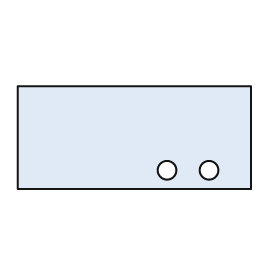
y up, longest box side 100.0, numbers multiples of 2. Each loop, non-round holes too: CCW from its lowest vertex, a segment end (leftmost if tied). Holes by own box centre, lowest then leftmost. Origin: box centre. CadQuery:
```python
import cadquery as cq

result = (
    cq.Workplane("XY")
    .moveTo(-50.0, -22.0)
    .lineTo(50.0, -22.0)
    .lineTo(50.0, 22.0)
    .lineTo(-50.0, 22.0)
    .close()
    .moveTo(14.0, -14.0)
    .circle(4.0)
    .moveTo(32.0, -14.0)
    .circle(4.0)
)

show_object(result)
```